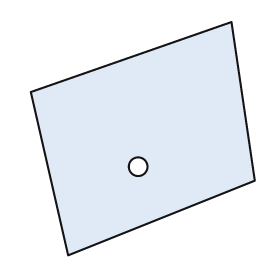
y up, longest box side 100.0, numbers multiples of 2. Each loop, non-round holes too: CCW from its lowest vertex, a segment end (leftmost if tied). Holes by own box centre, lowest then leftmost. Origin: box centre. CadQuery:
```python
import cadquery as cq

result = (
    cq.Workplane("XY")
    .moveTo(-32.0, -50.0)
    .lineTo(48.0, -18.0)
    .lineTo(38.0, 50.0)
    .lineTo(-48.0, 20.0)
    .close()
    .moveTo(-2.0, -12.0)
    .circle(4.0)
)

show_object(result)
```